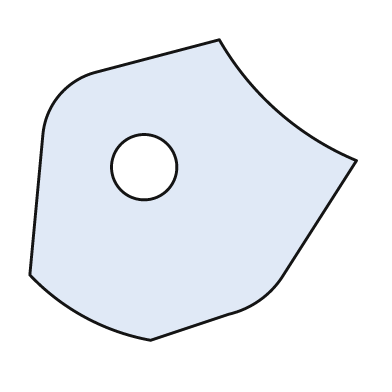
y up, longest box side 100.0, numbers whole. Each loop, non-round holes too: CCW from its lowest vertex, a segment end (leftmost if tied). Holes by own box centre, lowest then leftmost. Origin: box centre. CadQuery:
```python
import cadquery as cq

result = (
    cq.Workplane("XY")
    .moveTo(-13.0, -46.0)
    .lineTo(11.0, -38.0)
    .threePointArc((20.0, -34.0), (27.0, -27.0))
    .lineTo(50.0, 9.0)
    .threePointArc((26.0, 24.0), (8.0, 46.0))
    .lineTo(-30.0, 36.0)
    .threePointArc((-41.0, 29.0), (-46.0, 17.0))
    .lineTo(-50.0, -26.0)
    .threePointArc((-33.0, -39.0), (-13.0, -46.0))
    .close()
    .moveTo(-15.0, 7.0)
    .circle(10.0)
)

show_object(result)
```